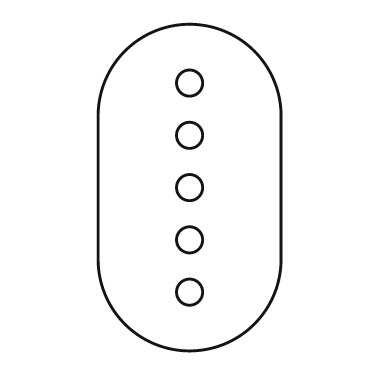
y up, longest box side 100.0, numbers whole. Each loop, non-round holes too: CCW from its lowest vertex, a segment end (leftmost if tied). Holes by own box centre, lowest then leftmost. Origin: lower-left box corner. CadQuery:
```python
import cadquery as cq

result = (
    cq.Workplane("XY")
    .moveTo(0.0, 28.0)
    .threePointArc((28.0, 0.0), (56.0, 28.0))
    .lineTo(56.0, 72.0)
    .threePointArc((28.0, 100.0), (0.0, 72.0))
    .close()
    .moveTo(28.0, 18.0)
    .circle(4.0)
    .moveTo(28.0, 34.0)
    .circle(4.0)
    .moveTo(28.0, 50.0)
    .circle(4.0)
    .moveTo(28.0, 66.0)
    .circle(4.0)
    .moveTo(28.0, 82.0)
    .circle(4.0)
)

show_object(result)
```